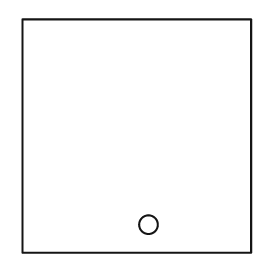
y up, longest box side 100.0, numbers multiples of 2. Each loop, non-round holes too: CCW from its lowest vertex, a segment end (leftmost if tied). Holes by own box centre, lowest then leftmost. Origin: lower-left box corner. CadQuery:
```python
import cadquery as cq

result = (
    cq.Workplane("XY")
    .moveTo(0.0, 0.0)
    .lineTo(98.0, 0.0)
    .lineTo(98.0, 100.0)
    .lineTo(0.0, 100.0)
    .close()
    .moveTo(54.0, 12.0)
    .circle(4.0)
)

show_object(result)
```